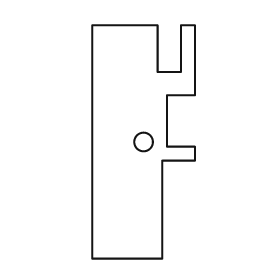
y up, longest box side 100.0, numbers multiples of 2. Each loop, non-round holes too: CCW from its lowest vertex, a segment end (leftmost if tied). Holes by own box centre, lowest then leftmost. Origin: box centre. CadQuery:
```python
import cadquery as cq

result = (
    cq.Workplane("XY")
    .moveTo(-22.0, -50.0)
    .lineTo(8.0, -50.0)
    .lineTo(8.0, -8.0)
    .lineTo(22.0, -8.0)
    .lineTo(22.0, -2.0)
    .lineTo(10.0, -2.0)
    .lineTo(10.0, 20.0)
    .lineTo(22.0, 20.0)
    .lineTo(22.0, 50.0)
    .lineTo(16.0, 50.0)
    .lineTo(16.0, 30.0)
    .lineTo(6.0, 30.0)
    .lineTo(6.0, 50.0)
    .lineTo(-22.0, 50.0)
    .close()
    .moveTo(0.0, 0.0)
    .circle(4.0)
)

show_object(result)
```